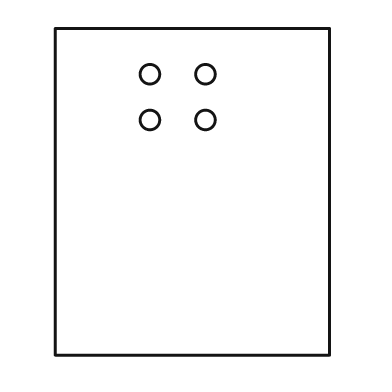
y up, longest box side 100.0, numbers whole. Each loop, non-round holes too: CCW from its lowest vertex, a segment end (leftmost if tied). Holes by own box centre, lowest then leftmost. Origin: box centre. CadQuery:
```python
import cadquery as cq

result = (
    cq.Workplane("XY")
    .moveTo(-42.0, -50.0)
    .lineTo(42.0, -50.0)
    .lineTo(42.0, 50.0)
    .lineTo(-42.0, 50.0)
    .close()
    .moveTo(-13.0, 22.0)
    .circle(3.0)
    .moveTo(4.0, 22.0)
    .circle(3.0)
    .moveTo(-13.0, 36.0)
    .circle(3.0)
    .moveTo(4.0, 36.0)
    .circle(3.0)
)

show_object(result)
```